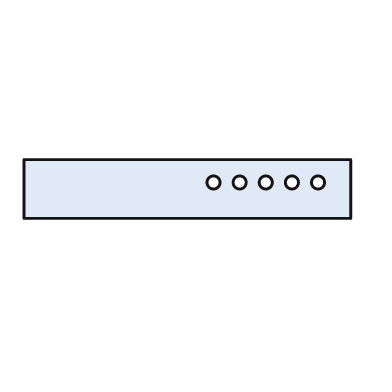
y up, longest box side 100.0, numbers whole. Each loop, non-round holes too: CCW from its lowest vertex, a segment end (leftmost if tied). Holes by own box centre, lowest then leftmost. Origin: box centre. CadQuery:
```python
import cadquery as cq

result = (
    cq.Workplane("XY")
    .moveTo(-50.0, -9.0)
    .lineTo(50.0, -9.0)
    .lineTo(50.0, 9.0)
    .lineTo(-50.0, 9.0)
    .close()
    .moveTo(8.0, 2.0)
    .circle(2.0)
    .moveTo(16.0, 2.0)
    .circle(2.0)
    .moveTo(24.0, 2.0)
    .circle(2.0)
    .moveTo(32.0, 2.0)
    .circle(2.0)
    .moveTo(40.0, 2.0)
    .circle(2.0)
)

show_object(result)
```